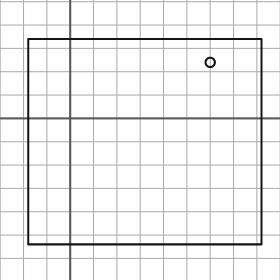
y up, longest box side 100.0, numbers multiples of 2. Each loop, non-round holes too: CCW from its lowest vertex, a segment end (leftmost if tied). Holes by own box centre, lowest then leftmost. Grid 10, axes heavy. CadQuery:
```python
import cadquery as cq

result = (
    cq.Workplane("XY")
    .moveTo(-18.0, -54.0)
    .lineTo(82.0, -54.0)
    .lineTo(82.0, 34.0)
    .lineTo(-18.0, 34.0)
    .close()
    .moveTo(60.0, 24.0)
    .circle(2.0)
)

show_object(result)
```